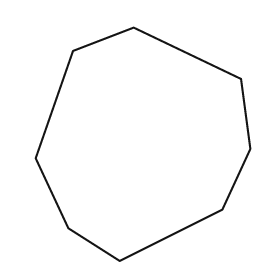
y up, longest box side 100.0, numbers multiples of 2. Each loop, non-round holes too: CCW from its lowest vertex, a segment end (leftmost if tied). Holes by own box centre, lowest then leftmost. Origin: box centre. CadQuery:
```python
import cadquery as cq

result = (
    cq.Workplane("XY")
    .moveTo(-10.0, -50.0)
    .lineTo(34.0, -28.0)
    .lineTo(46.0, -2.0)
    .lineTo(42.0, 28.0)
    .lineTo(-4.0, 50.0)
    .lineTo(-30.0, 40.0)
    .lineTo(-46.0, -6.0)
    .lineTo(-32.0, -36.0)
    .close()
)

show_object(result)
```